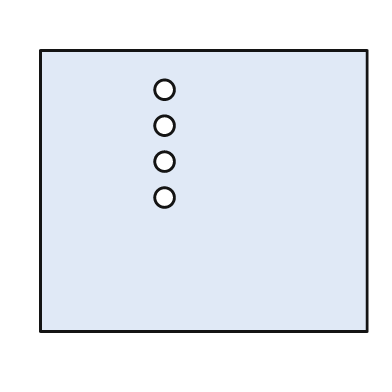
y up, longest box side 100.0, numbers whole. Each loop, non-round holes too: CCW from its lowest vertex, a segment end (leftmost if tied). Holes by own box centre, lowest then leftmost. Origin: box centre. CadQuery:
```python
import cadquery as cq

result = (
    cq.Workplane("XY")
    .moveTo(-50.0, -43.0)
    .lineTo(50.0, -43.0)
    .lineTo(50.0, 43.0)
    .lineTo(-50.0, 43.0)
    .close()
    .moveTo(-12.0, -2.0)
    .circle(3.0)
    .moveTo(-12.0, 9.0)
    .circle(3.0)
    .moveTo(-12.0, 20.0)
    .circle(3.0)
    .moveTo(-12.0, 31.0)
    .circle(3.0)
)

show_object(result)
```